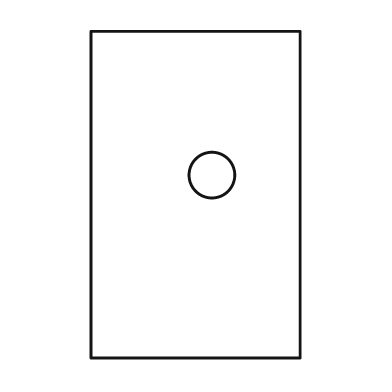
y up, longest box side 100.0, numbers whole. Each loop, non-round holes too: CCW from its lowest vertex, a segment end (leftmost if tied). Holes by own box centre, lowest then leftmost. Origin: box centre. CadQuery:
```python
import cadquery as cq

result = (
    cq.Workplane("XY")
    .moveTo(-32.0, -50.0)
    .lineTo(32.0, -50.0)
    .lineTo(32.0, 50.0)
    .lineTo(-32.0, 50.0)
    .close()
    .moveTo(5.0, 6.0)
    .circle(7.0)
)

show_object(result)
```